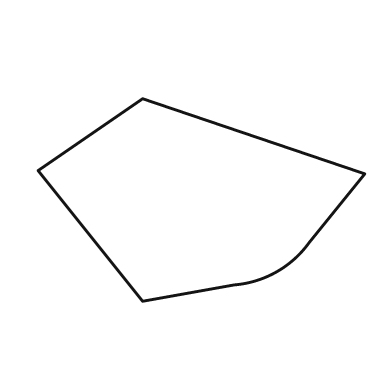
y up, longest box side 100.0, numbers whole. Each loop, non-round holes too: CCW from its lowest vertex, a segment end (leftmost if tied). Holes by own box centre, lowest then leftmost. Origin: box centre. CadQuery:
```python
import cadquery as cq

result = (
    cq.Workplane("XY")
    .moveTo(-18.0, -31.0)
    .lineTo(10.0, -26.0)
    .threePointArc((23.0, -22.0), (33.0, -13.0))
    .lineTo(50.0, 8.0)
    .lineTo(-18.0, 31.0)
    .lineTo(-50.0, 9.0)
    .close()
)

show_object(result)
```